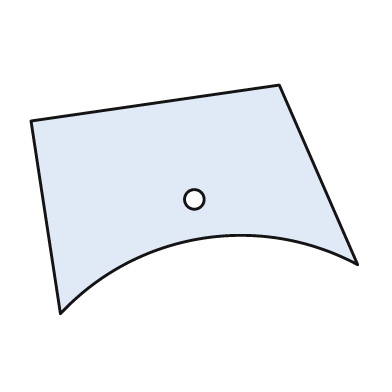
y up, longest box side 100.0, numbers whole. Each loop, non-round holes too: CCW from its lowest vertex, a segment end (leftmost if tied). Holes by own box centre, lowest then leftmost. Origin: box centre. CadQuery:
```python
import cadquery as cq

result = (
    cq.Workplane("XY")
    .moveTo(-41.0, -35.0)
    .threePointArc((2.0, -12.0), (50.0, -20.0))
    .lineTo(26.0, 35.0)
    .lineTo(-50.0, 24.0)
    .close()
    .moveTo(0.0, 0.0)
    .circle(3.0)
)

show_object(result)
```